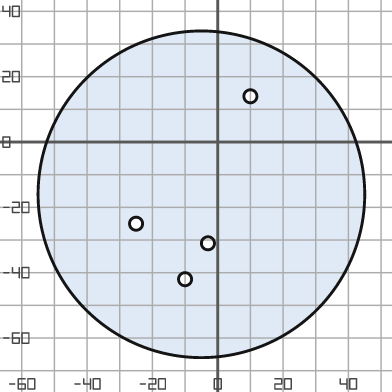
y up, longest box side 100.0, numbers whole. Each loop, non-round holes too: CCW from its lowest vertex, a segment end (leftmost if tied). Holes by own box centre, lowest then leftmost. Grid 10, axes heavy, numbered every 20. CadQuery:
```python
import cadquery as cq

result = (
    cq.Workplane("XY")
    .moveTo(-5.0, -16.0)
    .circle(50.0)
    .moveTo(-10.0, -42.0)
    .circle(2.0)
    .moveTo(-3.0, -31.0)
    .circle(2.0)
    .moveTo(-25.0, -25.0)
    .circle(2.0)
    .moveTo(10.0, 14.0)
    .circle(2.0)
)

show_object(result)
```